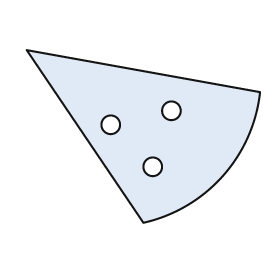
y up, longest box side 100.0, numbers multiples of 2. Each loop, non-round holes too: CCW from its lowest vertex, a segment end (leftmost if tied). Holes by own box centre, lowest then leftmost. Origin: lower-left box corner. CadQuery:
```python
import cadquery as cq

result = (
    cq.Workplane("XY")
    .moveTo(50.0, 0.0)
    .threePointArc((84.0, 20.0), (100.0, 56.0))
    .lineTo(0.0, 74.0)
    .close()
    .moveTo(54.0, 24.0)
    .circle(4.0)
    .moveTo(36.0, 42.0)
    .circle(4.0)
    .moveTo(62.0, 48.0)
    .circle(4.0)
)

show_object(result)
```